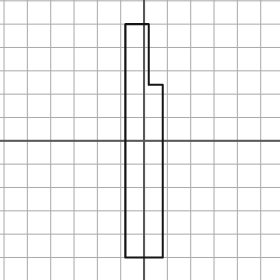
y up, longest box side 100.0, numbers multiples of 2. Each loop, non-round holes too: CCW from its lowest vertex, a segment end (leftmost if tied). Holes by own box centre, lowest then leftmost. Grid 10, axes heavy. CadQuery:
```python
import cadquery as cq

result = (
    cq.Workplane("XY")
    .moveTo(-8.0, -50.0)
    .lineTo(8.0, -50.0)
    .lineTo(8.0, 24.0)
    .lineTo(2.0, 24.0)
    .lineTo(2.0, 50.0)
    .lineTo(-8.0, 50.0)
    .close()
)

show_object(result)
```